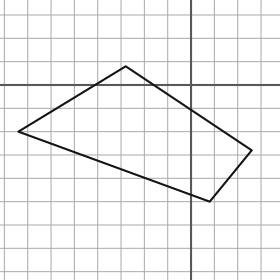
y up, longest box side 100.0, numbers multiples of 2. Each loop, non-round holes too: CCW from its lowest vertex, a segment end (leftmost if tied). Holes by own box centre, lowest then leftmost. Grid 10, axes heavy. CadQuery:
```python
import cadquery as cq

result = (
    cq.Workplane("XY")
    .moveTo(8.0, -50.0)
    .lineTo(26.0, -28.0)
    .lineTo(-28.0, 8.0)
    .lineTo(-74.0, -20.0)
    .close()
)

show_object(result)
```